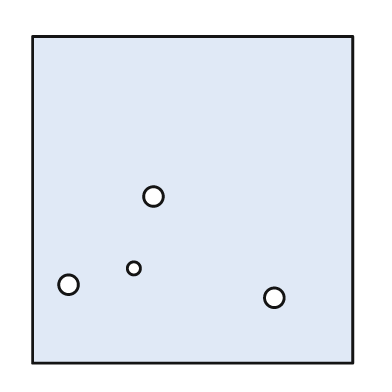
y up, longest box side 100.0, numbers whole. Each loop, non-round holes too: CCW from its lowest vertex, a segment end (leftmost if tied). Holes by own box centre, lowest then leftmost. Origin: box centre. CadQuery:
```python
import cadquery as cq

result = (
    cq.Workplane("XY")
    .moveTo(-49.0, -50.0)
    .lineTo(49.0, -50.0)
    .lineTo(49.0, 50.0)
    .lineTo(-49.0, 50.0)
    .close()
    .moveTo(25.0, -30.0)
    .circle(3.0)
    .moveTo(-38.0, -26.0)
    .circle(3.0)
    .moveTo(-18.0, -21.0)
    .circle(2.0)
    .moveTo(-12.0, 1.0)
    .circle(3.0)
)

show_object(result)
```